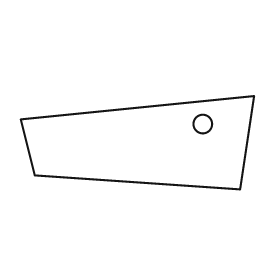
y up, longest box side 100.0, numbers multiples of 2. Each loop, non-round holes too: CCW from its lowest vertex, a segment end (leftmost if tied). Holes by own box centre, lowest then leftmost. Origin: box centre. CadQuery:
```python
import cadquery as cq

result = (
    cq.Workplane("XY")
    .moveTo(44.0, -20.0)
    .lineTo(50.0, 20.0)
    .lineTo(-50.0, 10.0)
    .lineTo(-44.0, -14.0)
    .close()
    .moveTo(28.0, 8.0)
    .circle(4.0)
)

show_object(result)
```